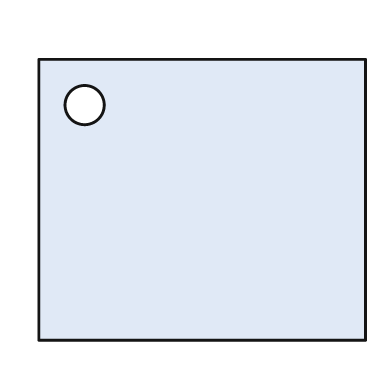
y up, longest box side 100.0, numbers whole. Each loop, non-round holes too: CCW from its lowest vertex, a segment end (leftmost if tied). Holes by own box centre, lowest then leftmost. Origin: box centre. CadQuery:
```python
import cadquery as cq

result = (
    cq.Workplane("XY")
    .moveTo(-50.0, -43.0)
    .lineTo(50.0, -43.0)
    .lineTo(50.0, 43.0)
    .lineTo(-50.0, 43.0)
    .close()
    .moveTo(-36.0, 29.0)
    .circle(6.0)
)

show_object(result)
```